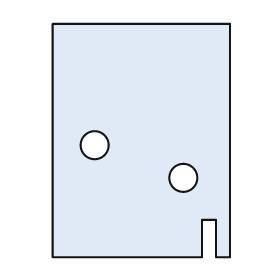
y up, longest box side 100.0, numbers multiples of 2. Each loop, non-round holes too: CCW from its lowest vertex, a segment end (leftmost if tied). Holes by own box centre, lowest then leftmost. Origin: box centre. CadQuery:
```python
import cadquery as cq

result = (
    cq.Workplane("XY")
    .moveTo(-38.0, -50.0)
    .lineTo(26.0, -50.0)
    .lineTo(26.0, -34.0)
    .lineTo(32.0, -34.0)
    .lineTo(32.0, -50.0)
    .lineTo(38.0, -50.0)
    .lineTo(38.0, 50.0)
    .lineTo(-38.0, 50.0)
    .close()
    .moveTo(18.0, -16.0)
    .circle(6.0)
    .moveTo(-20.0, -2.0)
    .circle(6.0)
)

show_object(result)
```